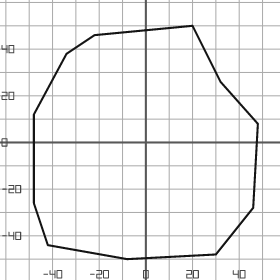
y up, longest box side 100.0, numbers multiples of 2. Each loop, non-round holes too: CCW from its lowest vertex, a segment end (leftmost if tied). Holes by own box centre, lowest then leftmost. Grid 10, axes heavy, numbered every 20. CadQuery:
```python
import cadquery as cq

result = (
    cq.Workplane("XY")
    .moveTo(-8.0, -50.0)
    .lineTo(30.0, -48.0)
    .lineTo(46.0, -28.0)
    .lineTo(48.0, 8.0)
    .lineTo(32.0, 26.0)
    .lineTo(20.0, 50.0)
    .lineTo(-22.0, 46.0)
    .lineTo(-34.0, 38.0)
    .lineTo(-48.0, 12.0)
    .lineTo(-48.0, -26.0)
    .lineTo(-42.0, -44.0)
    .close()
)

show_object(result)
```